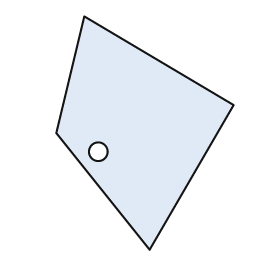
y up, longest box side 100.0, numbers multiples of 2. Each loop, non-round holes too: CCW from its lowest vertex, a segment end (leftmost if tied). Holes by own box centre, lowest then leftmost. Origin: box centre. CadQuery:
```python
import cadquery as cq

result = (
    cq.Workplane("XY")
    .moveTo(2.0, -50.0)
    .lineTo(38.0, 12.0)
    .lineTo(-26.0, 50.0)
    .lineTo(-38.0, 0.0)
    .close()
    .moveTo(-20.0, -8.0)
    .circle(4.0)
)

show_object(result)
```